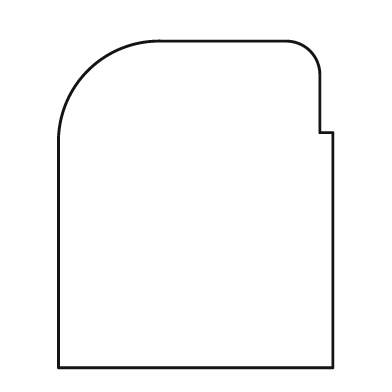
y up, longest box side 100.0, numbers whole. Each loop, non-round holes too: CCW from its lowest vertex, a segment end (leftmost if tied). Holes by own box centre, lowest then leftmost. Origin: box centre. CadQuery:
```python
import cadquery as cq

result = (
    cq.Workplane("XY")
    .moveTo(-42.0, -50.0)
    .lineTo(42.0, -50.0)
    .lineTo(42.0, 22.0)
    .lineTo(38.0, 22.0)
    .lineTo(38.0, 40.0)
    .threePointArc((35.0, 47.0), (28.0, 50.0))
    .lineTo(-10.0, 50.0)
    .threePointArc((-33.0, 41.0), (-42.0, 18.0))
    .close()
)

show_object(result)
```